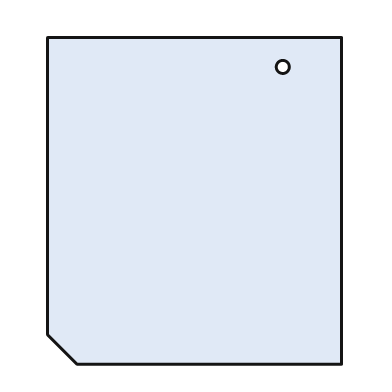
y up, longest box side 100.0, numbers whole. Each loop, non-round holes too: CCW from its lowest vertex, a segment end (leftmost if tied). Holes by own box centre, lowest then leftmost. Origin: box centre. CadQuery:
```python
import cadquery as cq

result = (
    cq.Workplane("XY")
    .moveTo(-36.0, -50.0)
    .lineTo(45.0, -50.0)
    .lineTo(45.0, 50.0)
    .lineTo(-45.0, 50.0)
    .lineTo(-45.0, -41.0)
    .close()
    .moveTo(27.0, 41.0)
    .circle(2.0)
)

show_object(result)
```